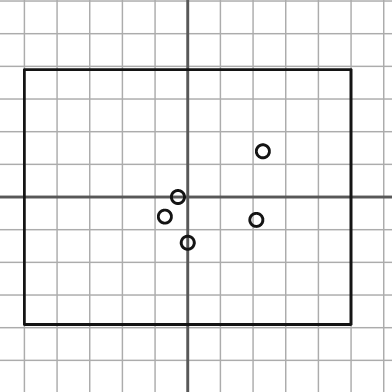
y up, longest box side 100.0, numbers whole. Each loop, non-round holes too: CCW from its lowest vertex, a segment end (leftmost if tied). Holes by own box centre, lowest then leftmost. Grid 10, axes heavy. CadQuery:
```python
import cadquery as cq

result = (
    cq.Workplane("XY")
    .moveTo(-50.0, -39.0)
    .lineTo(50.0, -39.0)
    .lineTo(50.0, 39.0)
    .lineTo(-50.0, 39.0)
    .close()
    .moveTo(0.0, -14.0)
    .circle(2.0)
    .moveTo(21.0, -7.0)
    .circle(2.0)
    .moveTo(-7.0, -6.0)
    .circle(2.0)
    .moveTo(-3.0, 0.0)
    .circle(2.0)
    .moveTo(23.0, 14.0)
    .circle(2.0)
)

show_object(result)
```